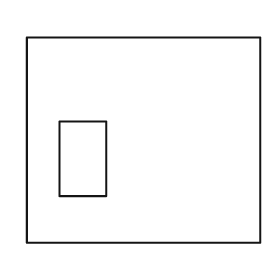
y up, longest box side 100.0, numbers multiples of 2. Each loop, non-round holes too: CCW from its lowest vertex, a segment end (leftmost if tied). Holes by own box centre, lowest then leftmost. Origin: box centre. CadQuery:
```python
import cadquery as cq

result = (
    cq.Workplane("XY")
    .moveTo(-50.0, -44.0)
    .lineTo(50.0, -44.0)
    .lineTo(50.0, 44.0)
    .lineTo(-50.0, 44.0)
    .close()
    .moveTo(-36.0, -24.0)
    .lineTo(-16.0, -24.0)
    .lineTo(-16.0, 8.0)
    .lineTo(-36.0, 8.0)
    .close()
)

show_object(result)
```